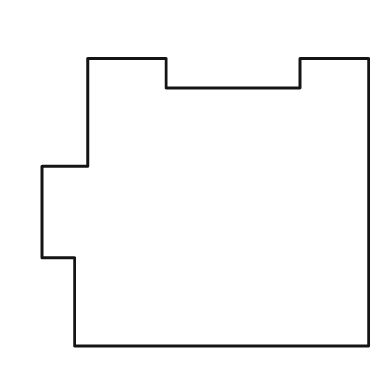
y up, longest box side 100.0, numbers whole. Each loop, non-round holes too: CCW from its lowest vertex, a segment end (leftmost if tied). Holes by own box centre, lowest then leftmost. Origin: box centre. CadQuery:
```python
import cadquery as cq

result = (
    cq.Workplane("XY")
    .moveTo(-40.0, -44.0)
    .lineTo(50.0, -44.0)
    .lineTo(50.0, 44.0)
    .lineTo(29.0, 44.0)
    .lineTo(29.0, 35.0)
    .lineTo(-12.0, 35.0)
    .lineTo(-12.0, 44.0)
    .lineTo(-36.0, 44.0)
    .lineTo(-36.0, 11.0)
    .lineTo(-50.0, 11.0)
    .lineTo(-50.0, -17.0)
    .lineTo(-40.0, -17.0)
    .close()
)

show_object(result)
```